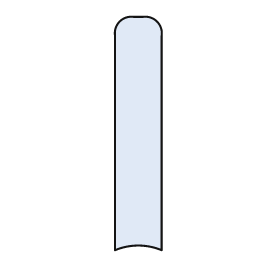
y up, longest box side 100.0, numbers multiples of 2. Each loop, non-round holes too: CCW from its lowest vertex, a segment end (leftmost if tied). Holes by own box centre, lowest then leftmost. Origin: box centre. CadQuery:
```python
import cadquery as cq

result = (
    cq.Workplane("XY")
    .moveTo(-10.0, -50.0)
    .threePointArc((0.0, -48.0), (10.0, -50.0))
    .lineTo(10.0, 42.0)
    .threePointArc((8.0, 48.0), (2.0, 50.0))
    .lineTo(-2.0, 50.0)
    .threePointArc((-8.0, 48.0), (-10.0, 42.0))
    .close()
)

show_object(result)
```